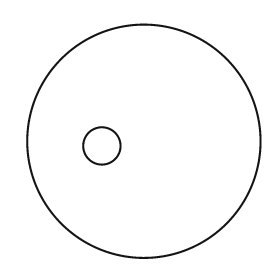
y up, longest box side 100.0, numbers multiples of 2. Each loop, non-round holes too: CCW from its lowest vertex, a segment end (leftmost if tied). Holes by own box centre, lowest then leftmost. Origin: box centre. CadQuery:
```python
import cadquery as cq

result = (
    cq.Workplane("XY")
    .moveTo(0.0, 0.0)
    .circle(50.0)
    .moveTo(-18.0, -2.0)
    .circle(8.0)
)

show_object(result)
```